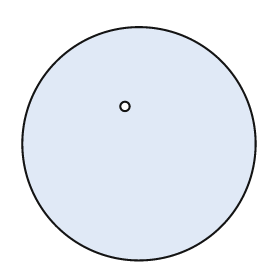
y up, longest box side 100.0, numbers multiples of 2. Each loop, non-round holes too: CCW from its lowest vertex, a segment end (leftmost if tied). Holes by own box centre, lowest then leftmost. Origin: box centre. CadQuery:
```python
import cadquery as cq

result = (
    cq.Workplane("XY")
    .moveTo(0.0, 0.0)
    .circle(50.0)
    .moveTo(-6.0, 16.0)
    .circle(2.0)
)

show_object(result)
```